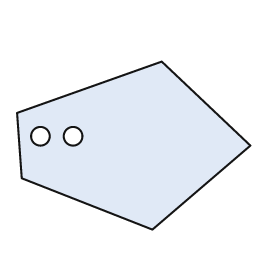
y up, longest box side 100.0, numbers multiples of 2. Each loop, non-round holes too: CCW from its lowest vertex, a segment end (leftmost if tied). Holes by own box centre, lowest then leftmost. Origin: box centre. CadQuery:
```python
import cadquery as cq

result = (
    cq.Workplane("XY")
    .moveTo(8.0, -36.0)
    .lineTo(50.0, 0.0)
    .lineTo(12.0, 36.0)
    .lineTo(-50.0, 14.0)
    .lineTo(-48.0, -14.0)
    .close()
    .moveTo(-40.0, 4.0)
    .circle(4.0)
    .moveTo(-26.0, 4.0)
    .circle(4.0)
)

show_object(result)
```